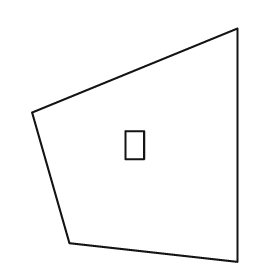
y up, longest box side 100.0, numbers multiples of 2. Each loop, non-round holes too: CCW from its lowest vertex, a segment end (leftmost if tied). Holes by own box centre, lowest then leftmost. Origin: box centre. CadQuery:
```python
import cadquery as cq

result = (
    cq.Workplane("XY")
    .moveTo(44.0, -50.0)
    .lineTo(44.0, 50.0)
    .lineTo(-44.0, 14.0)
    .lineTo(-28.0, -42.0)
    .close()
    .moveTo(-4.0, -6.0)
    .lineTo(4.0, -6.0)
    .lineTo(4.0, 6.0)
    .lineTo(-4.0, 6.0)
    .close()
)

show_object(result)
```